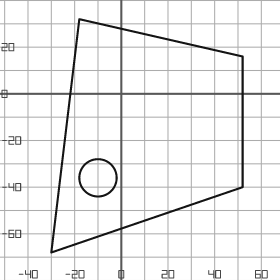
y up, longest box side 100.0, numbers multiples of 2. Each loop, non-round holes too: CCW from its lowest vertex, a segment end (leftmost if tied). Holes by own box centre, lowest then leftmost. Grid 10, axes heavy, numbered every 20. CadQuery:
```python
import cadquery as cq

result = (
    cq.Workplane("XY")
    .moveTo(-30.0, -68.0)
    .lineTo(52.0, -40.0)
    .lineTo(52.0, 16.0)
    .lineTo(-18.0, 32.0)
    .close()
    .moveTo(-10.0, -36.0)
    .circle(8.0)
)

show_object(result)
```